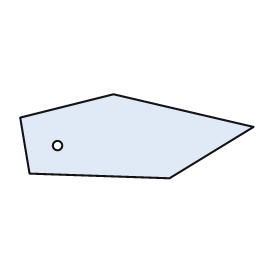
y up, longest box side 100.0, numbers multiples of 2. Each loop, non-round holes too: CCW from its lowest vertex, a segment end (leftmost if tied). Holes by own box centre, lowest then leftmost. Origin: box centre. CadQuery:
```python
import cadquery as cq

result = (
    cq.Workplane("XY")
    .moveTo(14.0, -18.0)
    .lineTo(50.0, 4.0)
    .lineTo(-10.0, 18.0)
    .lineTo(-50.0, 8.0)
    .lineTo(-46.0, -16.0)
    .close()
    .moveTo(-34.0, -4.0)
    .circle(2.0)
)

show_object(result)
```